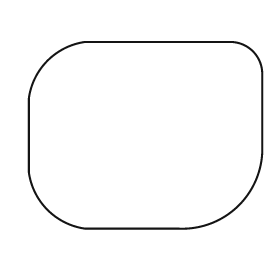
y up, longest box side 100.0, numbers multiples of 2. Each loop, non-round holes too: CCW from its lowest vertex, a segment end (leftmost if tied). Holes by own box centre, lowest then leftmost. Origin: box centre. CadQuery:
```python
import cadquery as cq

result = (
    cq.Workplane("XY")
    .moveTo(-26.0, -40.0)
    .lineTo(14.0, -40.0)
    .threePointArc((40.0, -30.0), (50.0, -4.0))
    .lineTo(50.0, 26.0)
    .threePointArc((46.0, 36.0), (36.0, 40.0))
    .lineTo(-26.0, 40.0)
    .threePointArc((-42.0, 32.0), (-50.0, 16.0))
    .lineTo(-50.0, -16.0)
    .threePointArc((-42.0, -32.0), (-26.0, -40.0))
    .close()
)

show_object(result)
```